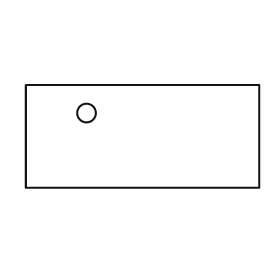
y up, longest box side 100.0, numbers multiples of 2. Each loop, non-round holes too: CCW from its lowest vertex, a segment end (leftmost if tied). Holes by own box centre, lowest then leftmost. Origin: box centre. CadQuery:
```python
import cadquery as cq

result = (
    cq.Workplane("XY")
    .moveTo(-50.0, -22.0)
    .lineTo(50.0, -22.0)
    .lineTo(50.0, 22.0)
    .lineTo(-50.0, 22.0)
    .close()
    .moveTo(-24.0, 10.0)
    .circle(4.0)
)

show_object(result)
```